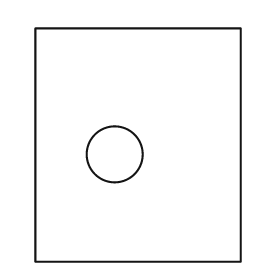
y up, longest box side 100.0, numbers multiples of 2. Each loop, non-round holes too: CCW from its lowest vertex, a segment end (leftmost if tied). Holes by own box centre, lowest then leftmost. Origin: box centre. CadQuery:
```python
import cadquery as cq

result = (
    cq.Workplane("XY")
    .moveTo(-44.0, -50.0)
    .lineTo(44.0, -50.0)
    .lineTo(44.0, 50.0)
    .lineTo(-44.0, 50.0)
    .close()
    .moveTo(-10.0, -4.0)
    .circle(12.0)
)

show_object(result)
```